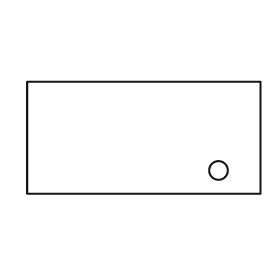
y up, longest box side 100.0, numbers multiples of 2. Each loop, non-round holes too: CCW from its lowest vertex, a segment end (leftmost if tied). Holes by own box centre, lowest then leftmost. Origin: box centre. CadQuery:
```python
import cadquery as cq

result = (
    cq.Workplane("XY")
    .moveTo(-50.0, -24.0)
    .lineTo(50.0, -24.0)
    .lineTo(50.0, 24.0)
    .lineTo(-50.0, 24.0)
    .close()
    .moveTo(32.0, -14.0)
    .circle(4.0)
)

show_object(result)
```